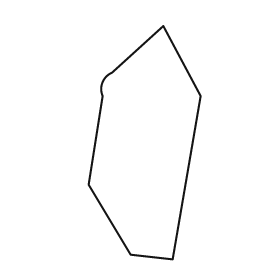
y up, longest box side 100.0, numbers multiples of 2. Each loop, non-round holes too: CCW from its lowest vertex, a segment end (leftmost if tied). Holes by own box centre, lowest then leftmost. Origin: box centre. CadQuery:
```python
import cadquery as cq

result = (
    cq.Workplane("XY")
    .moveTo(12.0, -50.0)
    .lineTo(24.0, 20.0)
    .lineTo(8.0, 50.0)
    .lineTo(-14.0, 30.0)
    .threePointArc((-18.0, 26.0), (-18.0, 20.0))
    .lineTo(-24.0, -18.0)
    .lineTo(-6.0, -48.0)
    .close()
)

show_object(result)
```